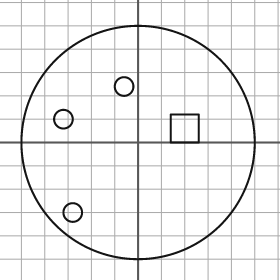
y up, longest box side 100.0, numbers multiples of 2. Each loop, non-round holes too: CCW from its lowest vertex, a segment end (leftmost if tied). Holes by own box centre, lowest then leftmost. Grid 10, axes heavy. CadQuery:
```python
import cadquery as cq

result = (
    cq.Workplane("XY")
    .moveTo(0.0, 0.0)
    .circle(50.0)
    .moveTo(-28.0, -30.0)
    .circle(4.0)
    .moveTo(14.0, 0.0)
    .lineTo(26.0, 0.0)
    .lineTo(26.0, 12.0)
    .lineTo(14.0, 12.0)
    .close()
    .moveTo(-32.0, 10.0)
    .circle(4.0)
    .moveTo(-6.0, 24.0)
    .circle(4.0)
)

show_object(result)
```